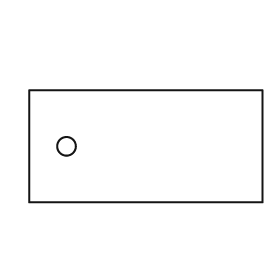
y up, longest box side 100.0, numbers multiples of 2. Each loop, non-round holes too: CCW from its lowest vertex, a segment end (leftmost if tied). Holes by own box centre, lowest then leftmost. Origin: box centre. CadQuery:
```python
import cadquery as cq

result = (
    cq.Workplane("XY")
    .moveTo(-50.0, -24.0)
    .lineTo(50.0, -24.0)
    .lineTo(50.0, 24.0)
    .lineTo(-50.0, 24.0)
    .close()
    .moveTo(-34.0, 0.0)
    .circle(4.0)
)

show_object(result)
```